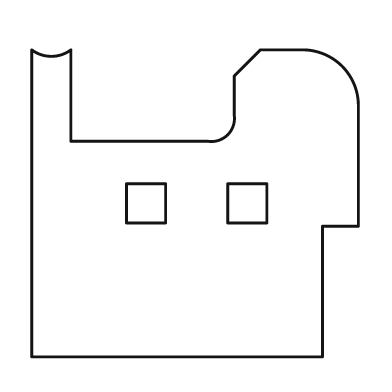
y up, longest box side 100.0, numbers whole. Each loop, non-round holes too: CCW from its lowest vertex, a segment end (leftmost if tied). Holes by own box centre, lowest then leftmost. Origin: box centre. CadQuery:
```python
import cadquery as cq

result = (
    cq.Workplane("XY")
    .moveTo(-50.0, -47.0)
    .lineTo(39.0, -47.0)
    .lineTo(39.0, -7.0)
    .lineTo(50.0, -7.0)
    .lineTo(50.0, 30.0)
    .threePointArc((45.0, 42.0), (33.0, 47.0))
    .lineTo(20.0, 47.0)
    .lineTo(12.0, 39.0)
    .lineTo(12.0, 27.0)
    .threePointArc((10.0, 21.0), (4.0, 19.0))
    .lineTo(-38.0, 19.0)
    .lineTo(-38.0, 47.0)
    .threePointArc((-44.0, 45.0), (-50.0, 47.0))
    .close()
    .moveTo(-21.0, -6.0)
    .lineTo(-9.0, -6.0)
    .lineTo(-9.0, 6.0)
    .lineTo(-21.0, 6.0)
    .close()
    .moveTo(10.0, -6.0)
    .lineTo(22.0, -6.0)
    .lineTo(22.0, 6.0)
    .lineTo(10.0, 6.0)
    .close()
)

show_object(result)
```